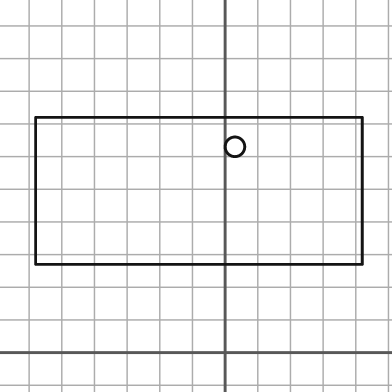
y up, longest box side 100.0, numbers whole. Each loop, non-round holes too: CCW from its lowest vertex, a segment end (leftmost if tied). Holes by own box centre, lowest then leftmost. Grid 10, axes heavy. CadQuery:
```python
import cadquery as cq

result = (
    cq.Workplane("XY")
    .moveTo(-58.0, 27.0)
    .lineTo(42.0, 27.0)
    .lineTo(42.0, 72.0)
    .lineTo(-58.0, 72.0)
    .close()
    .moveTo(3.0, 63.0)
    .circle(3.0)
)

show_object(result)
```